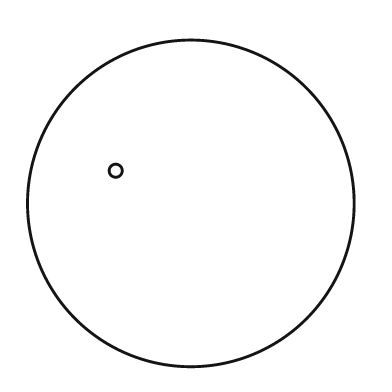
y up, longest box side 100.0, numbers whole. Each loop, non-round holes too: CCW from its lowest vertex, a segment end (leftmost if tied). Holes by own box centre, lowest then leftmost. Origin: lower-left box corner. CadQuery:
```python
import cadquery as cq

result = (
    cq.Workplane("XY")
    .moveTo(50.0, 50.0)
    .circle(50.0)
    .moveTo(27.0, 60.0)
    .circle(2.0)
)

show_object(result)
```